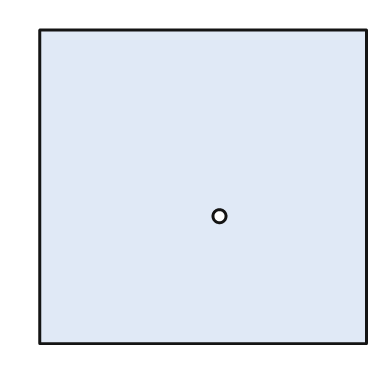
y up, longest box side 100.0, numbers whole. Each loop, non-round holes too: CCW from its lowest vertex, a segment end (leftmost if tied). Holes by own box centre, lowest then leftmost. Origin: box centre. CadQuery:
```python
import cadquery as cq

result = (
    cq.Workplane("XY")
    .moveTo(-50.0, -48.0)
    .lineTo(50.0, -48.0)
    .lineTo(50.0, 48.0)
    .lineTo(-50.0, 48.0)
    .close()
    .moveTo(5.0, -9.0)
    .circle(2.0)
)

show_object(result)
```